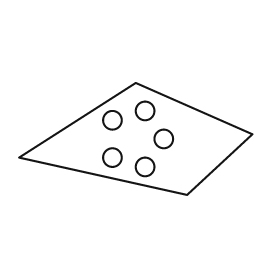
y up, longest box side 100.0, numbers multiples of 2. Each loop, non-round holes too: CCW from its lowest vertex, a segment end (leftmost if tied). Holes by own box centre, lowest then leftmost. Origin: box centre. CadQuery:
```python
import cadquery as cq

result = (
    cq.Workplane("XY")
    .moveTo(22.0, -24.0)
    .lineTo(50.0, 2.0)
    .lineTo(0.0, 24.0)
    .lineTo(-50.0, -8.0)
    .close()
    .moveTo(4.0, -12.0)
    .circle(4.0)
    .moveTo(-10.0, -8.0)
    .circle(4.0)
    .moveTo(12.0, 0.0)
    .circle(4.0)
    .moveTo(-10.0, 8.0)
    .circle(4.0)
    .moveTo(4.0, 12.0)
    .circle(4.0)
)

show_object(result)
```